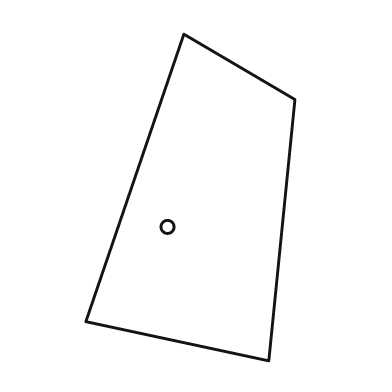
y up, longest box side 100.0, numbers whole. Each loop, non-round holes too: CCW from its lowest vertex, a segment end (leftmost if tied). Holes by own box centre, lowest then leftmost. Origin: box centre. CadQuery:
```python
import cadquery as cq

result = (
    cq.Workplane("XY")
    .moveTo(24.0, -50.0)
    .lineTo(32.0, 30.0)
    .lineTo(-2.0, 50.0)
    .lineTo(-32.0, -38.0)
    .close()
    .moveTo(-7.0, -9.0)
    .circle(2.0)
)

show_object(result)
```